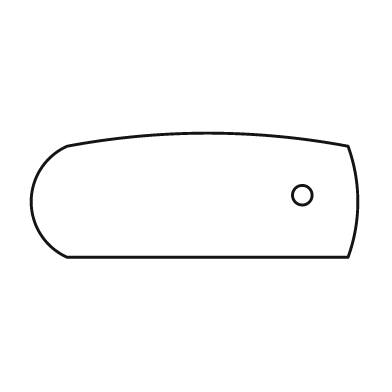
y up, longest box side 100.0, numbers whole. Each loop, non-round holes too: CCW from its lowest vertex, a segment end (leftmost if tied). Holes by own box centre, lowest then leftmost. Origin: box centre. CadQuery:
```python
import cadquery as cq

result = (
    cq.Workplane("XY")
    .moveTo(-39.0, -19.0)
    .lineTo(47.0, -19.0)
    .threePointArc((50.0, -2.0), (47.0, 15.0))
    .threePointArc((4.0, 19.0), (-39.0, 15.0))
    .threePointArc((-50.0, -2.0), (-39.0, -19.0))
    .close()
    .moveTo(33.0, 0.0)
    .circle(3.0)
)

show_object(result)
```